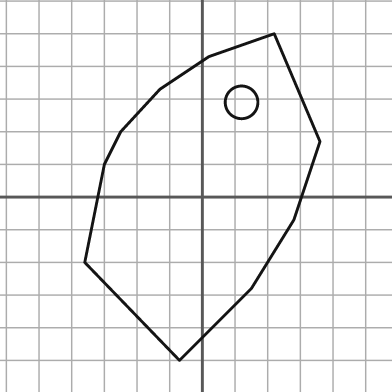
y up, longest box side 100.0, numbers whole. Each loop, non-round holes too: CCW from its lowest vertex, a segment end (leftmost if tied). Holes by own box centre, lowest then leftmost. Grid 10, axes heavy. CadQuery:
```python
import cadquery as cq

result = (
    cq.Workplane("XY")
    .moveTo(-7.0, -50.0)
    .lineTo(15.0, -28.0)
    .lineTo(28.0, -7.0)
    .lineTo(36.0, 17.0)
    .lineTo(22.0, 50.0)
    .lineTo(2.0, 43.0)
    .lineTo(-13.0, 33.0)
    .lineTo(-25.0, 20.0)
    .lineTo(-30.0, 10.0)
    .lineTo(-36.0, -20.0)
    .close()
    .moveTo(12.0, 29.0)
    .circle(5.0)
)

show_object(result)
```